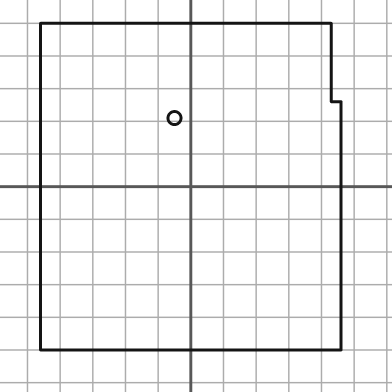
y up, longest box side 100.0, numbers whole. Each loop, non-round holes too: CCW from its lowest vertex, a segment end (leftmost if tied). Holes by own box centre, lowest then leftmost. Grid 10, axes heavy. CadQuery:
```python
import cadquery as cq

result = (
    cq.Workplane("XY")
    .moveTo(-46.0, -50.0)
    .lineTo(46.0, -50.0)
    .lineTo(46.0, 26.0)
    .lineTo(43.0, 26.0)
    .lineTo(43.0, 50.0)
    .lineTo(-46.0, 50.0)
    .close()
    .moveTo(-5.0, 21.0)
    .circle(2.0)
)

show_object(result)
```